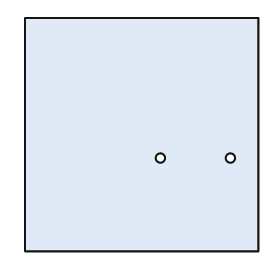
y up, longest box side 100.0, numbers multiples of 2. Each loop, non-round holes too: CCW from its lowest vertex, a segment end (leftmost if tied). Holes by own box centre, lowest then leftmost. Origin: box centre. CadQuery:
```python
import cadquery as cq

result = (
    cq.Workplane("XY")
    .moveTo(-50.0, -50.0)
    .lineTo(50.0, -50.0)
    .lineTo(50.0, 50.0)
    .lineTo(-50.0, 50.0)
    .close()
    .moveTo(8.0, -10.0)
    .circle(2.0)
    .moveTo(38.0, -10.0)
    .circle(2.0)
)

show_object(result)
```